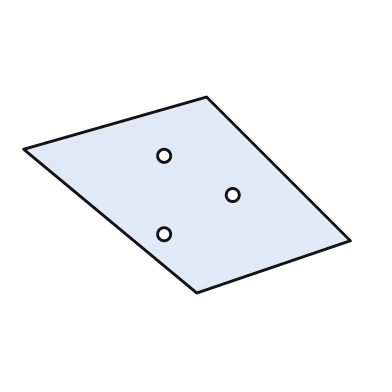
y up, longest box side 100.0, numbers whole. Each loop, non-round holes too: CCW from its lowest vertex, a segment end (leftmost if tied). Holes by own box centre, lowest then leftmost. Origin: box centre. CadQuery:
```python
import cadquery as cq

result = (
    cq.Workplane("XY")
    .moveTo(3.0, -30.0)
    .lineTo(50.0, -14.0)
    .lineTo(6.0, 30.0)
    .lineTo(-50.0, 14.0)
    .close()
    .moveTo(-7.0, -12.0)
    .circle(2.0)
    .moveTo(14.0, 0.0)
    .circle(2.0)
    .moveTo(-7.0, 12.0)
    .circle(2.0)
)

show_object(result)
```